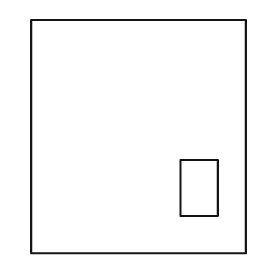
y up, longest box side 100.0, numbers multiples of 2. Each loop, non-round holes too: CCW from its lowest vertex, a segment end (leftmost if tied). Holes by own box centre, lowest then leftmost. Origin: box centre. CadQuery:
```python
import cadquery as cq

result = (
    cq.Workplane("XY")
    .moveTo(-46.0, -50.0)
    .lineTo(46.0, -50.0)
    .lineTo(46.0, 50.0)
    .lineTo(-46.0, 50.0)
    .close()
    .moveTo(18.0, -34.0)
    .lineTo(34.0, -34.0)
    .lineTo(34.0, -10.0)
    .lineTo(18.0, -10.0)
    .close()
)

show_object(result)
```